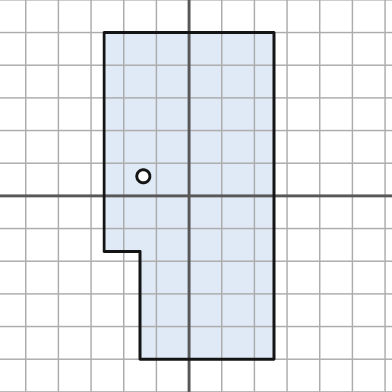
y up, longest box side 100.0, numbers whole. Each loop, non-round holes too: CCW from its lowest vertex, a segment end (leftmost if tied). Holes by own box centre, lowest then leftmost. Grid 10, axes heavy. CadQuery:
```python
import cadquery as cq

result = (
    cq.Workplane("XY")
    .moveTo(-15.0, -50.0)
    .lineTo(26.0, -50.0)
    .lineTo(26.0, 50.0)
    .lineTo(-26.0, 50.0)
    .lineTo(-26.0, -17.0)
    .lineTo(-15.0, -17.0)
    .close()
    .moveTo(-14.0, 6.0)
    .circle(2.0)
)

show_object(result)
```